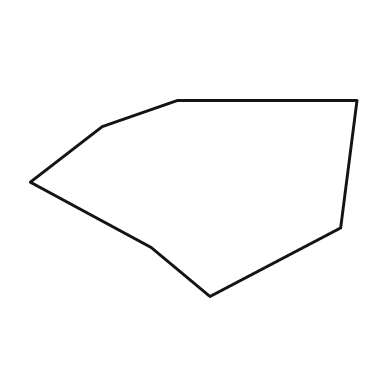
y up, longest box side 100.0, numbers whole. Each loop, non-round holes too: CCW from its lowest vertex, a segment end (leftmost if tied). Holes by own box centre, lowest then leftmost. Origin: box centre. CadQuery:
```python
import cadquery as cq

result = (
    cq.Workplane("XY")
    .moveTo(5.0, -30.0)
    .lineTo(45.0, -9.0)
    .lineTo(50.0, 30.0)
    .lineTo(-5.0, 30.0)
    .lineTo(-28.0, 22.0)
    .lineTo(-50.0, 5.0)
    .lineTo(-13.0, -15.0)
    .close()
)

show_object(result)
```